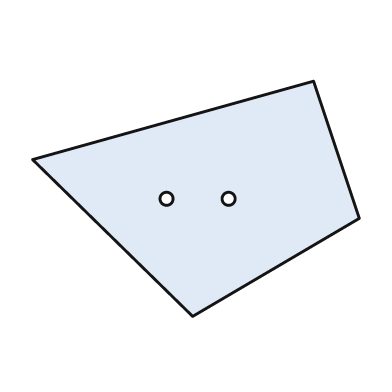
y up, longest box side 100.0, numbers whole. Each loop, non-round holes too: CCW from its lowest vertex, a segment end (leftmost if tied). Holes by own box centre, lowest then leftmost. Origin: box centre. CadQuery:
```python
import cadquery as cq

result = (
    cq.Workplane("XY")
    .moveTo(-1.0, -36.0)
    .lineTo(50.0, -6.0)
    .lineTo(36.0, 36.0)
    .lineTo(-50.0, 12.0)
    .close()
    .moveTo(-9.0, 0.0)
    .circle(2.0)
    .moveTo(10.0, 0.0)
    .circle(2.0)
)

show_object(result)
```